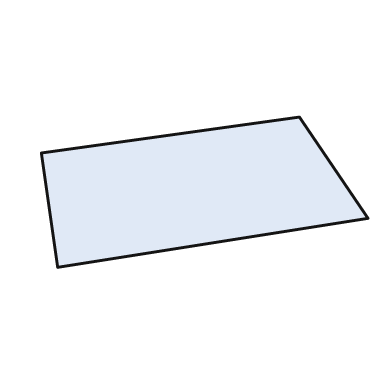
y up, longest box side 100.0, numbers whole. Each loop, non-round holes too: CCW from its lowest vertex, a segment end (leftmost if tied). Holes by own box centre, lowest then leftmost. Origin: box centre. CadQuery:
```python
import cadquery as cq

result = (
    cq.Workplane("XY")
    .moveTo(-45.0, -23.0)
    .lineTo(50.0, -8.0)
    .lineTo(29.0, 23.0)
    .lineTo(-50.0, 12.0)
    .close()
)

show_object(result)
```